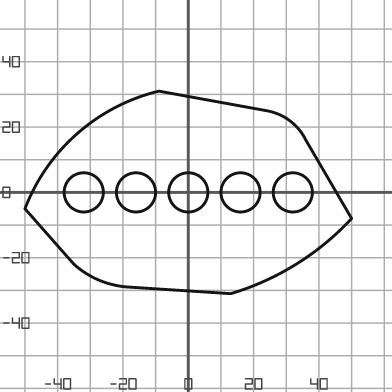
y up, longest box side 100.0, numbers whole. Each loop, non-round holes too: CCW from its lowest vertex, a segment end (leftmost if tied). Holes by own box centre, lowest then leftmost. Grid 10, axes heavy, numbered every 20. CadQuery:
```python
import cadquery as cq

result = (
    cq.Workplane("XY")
    .moveTo(13.0, -31.0)
    .threePointArc((33.0, -22.0), (50.0, -8.0))
    .lineTo(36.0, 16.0)
    .threePointArc((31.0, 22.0), (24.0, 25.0))
    .lineTo(-9.0, 31.0)
    .threePointArc((-34.0, 18.0), (-50.0, -5.0))
    .lineTo(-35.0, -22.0)
    .threePointArc((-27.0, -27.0), (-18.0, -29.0))
    .close()
    .moveTo(-32.0, 0.0)
    .circle(6.0)
    .moveTo(-16.0, 0.0)
    .circle(6.0)
    .moveTo(0.0, 0.0)
    .circle(6.0)
    .moveTo(16.0, 0.0)
    .circle(6.0)
    .moveTo(32.0, 0.0)
    .circle(6.0)
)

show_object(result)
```